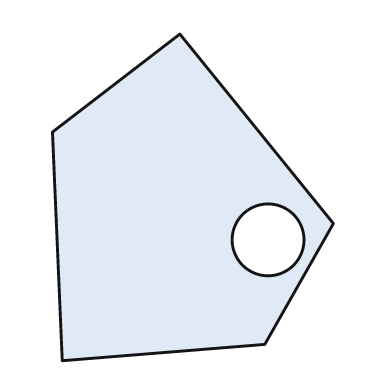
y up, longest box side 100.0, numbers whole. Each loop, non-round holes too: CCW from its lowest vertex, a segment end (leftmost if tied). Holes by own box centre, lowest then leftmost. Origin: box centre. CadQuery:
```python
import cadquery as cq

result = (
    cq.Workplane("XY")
    .moveTo(-40.0, -50.0)
    .lineTo(22.0, -45.0)
    .lineTo(43.0, -8.0)
    .lineTo(-4.0, 50.0)
    .lineTo(-43.0, 20.0)
    .close()
    .moveTo(23.0, -13.0)
    .circle(11.0)
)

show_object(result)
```